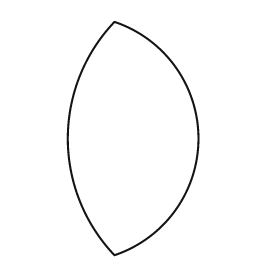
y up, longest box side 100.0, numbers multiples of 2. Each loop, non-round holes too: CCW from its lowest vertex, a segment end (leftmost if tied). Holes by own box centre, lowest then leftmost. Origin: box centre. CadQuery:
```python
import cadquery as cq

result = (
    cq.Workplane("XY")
    .moveTo(-8.0, -50.0)
    .threePointArc((28.0, 0.0), (-8.0, 50.0))
    .threePointArc((-28.0, 0.0), (-8.0, -50.0))
    .close()
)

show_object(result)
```